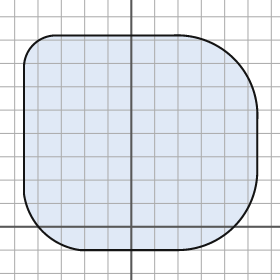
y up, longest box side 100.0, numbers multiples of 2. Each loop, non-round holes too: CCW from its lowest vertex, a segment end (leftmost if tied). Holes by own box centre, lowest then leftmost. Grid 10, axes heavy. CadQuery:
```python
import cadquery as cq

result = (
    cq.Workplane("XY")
    .moveTo(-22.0, -10.0)
    .lineTo(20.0, -10.0)
    .threePointArc((44.0, 0.0), (54.0, 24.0))
    .lineTo(54.0, 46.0)
    .threePointArc((44.0, 72.0), (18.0, 82.0))
    .lineTo(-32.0, 82.0)
    .threePointArc((-42.0, 78.0), (-46.0, 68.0))
    .lineTo(-46.0, 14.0)
    .threePointArc((-38.0, -2.0), (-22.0, -10.0))
    .close()
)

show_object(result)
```